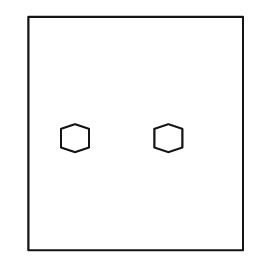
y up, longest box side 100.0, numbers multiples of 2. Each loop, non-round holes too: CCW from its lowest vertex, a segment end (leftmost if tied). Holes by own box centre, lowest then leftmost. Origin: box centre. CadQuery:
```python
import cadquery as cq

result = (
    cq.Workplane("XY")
    .moveTo(-46.0, -50.0)
    .lineTo(46.0, -50.0)
    .lineTo(46.0, 50.0)
    .lineTo(-46.0, 50.0)
    .close()
    .moveTo(-26.0, -8.0)
    .lineTo(-20.0, -6.0)
    .lineTo(-20.0, 2.0)
    .lineTo(-26.0, 4.0)
    .lineTo(-32.0, 2.0)
    .lineTo(-32.0, -6.0)
    .close()
    .moveTo(14.0, -8.0)
    .lineTo(20.0, -6.0)
    .lineTo(20.0, 2.0)
    .lineTo(14.0, 4.0)
    .lineTo(8.0, 2.0)
    .lineTo(8.0, -6.0)
    .close()
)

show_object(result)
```